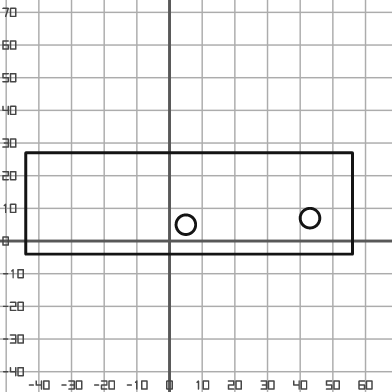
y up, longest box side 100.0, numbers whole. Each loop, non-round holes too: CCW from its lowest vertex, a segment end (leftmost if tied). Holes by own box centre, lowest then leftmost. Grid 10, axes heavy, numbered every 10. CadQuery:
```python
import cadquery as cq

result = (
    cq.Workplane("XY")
    .moveTo(-44.0, -4.0)
    .lineTo(56.0, -4.0)
    .lineTo(56.0, 27.0)
    .lineTo(-44.0, 27.0)
    .close()
    .moveTo(5.0, 5.0)
    .circle(3.0)
    .moveTo(43.0, 7.0)
    .circle(3.0)
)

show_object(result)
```